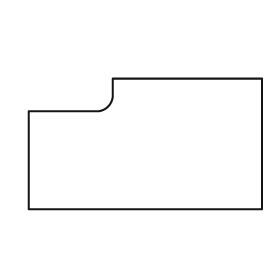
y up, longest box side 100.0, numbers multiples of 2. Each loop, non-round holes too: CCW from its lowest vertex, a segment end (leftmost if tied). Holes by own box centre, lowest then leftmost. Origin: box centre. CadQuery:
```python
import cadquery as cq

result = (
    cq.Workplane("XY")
    .moveTo(-50.0, -28.0)
    .lineTo(50.0, -28.0)
    .lineTo(50.0, 28.0)
    .lineTo(-14.0, 28.0)
    .lineTo(-14.0, 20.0)
    .threePointArc((-16.0, 16.0), (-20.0, 14.0))
    .lineTo(-50.0, 14.0)
    .close()
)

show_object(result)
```